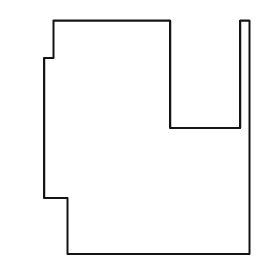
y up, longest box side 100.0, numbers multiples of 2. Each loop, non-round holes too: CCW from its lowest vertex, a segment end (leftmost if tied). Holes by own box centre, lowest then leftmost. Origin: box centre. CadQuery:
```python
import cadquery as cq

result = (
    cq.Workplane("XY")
    .moveTo(-34.0, -50.0)
    .lineTo(44.0, -50.0)
    .lineTo(44.0, 50.0)
    .lineTo(40.0, 50.0)
    .lineTo(40.0, 4.0)
    .lineTo(10.0, 4.0)
    .lineTo(10.0, 50.0)
    .lineTo(-40.0, 50.0)
    .lineTo(-40.0, 34.0)
    .lineTo(-44.0, 34.0)
    .lineTo(-44.0, -26.0)
    .lineTo(-34.0, -26.0)
    .close()
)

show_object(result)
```